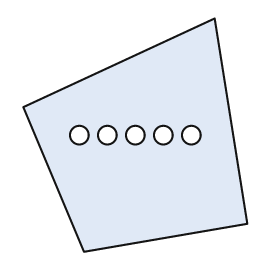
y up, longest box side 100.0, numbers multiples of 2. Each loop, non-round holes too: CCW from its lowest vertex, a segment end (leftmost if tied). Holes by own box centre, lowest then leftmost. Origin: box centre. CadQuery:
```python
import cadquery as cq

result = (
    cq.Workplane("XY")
    .moveTo(-22.0, -50.0)
    .lineTo(48.0, -38.0)
    .lineTo(34.0, 50.0)
    .lineTo(-48.0, 12.0)
    .close()
    .moveTo(-24.0, 0.0)
    .circle(4.0)
    .moveTo(-12.0, 0.0)
    .circle(4.0)
    .moveTo(0.0, 0.0)
    .circle(4.0)
    .moveTo(12.0, 0.0)
    .circle(4.0)
    .moveTo(24.0, 0.0)
    .circle(4.0)
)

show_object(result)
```